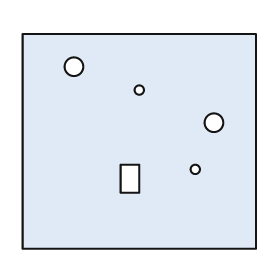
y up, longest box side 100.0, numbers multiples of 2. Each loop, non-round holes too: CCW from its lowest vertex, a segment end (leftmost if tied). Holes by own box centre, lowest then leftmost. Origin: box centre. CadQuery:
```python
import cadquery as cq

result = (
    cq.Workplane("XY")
    .moveTo(-50.0, -46.0)
    .lineTo(50.0, -46.0)
    .lineTo(50.0, 46.0)
    .lineTo(-50.0, 46.0)
    .close()
    .moveTo(-8.0, -22.0)
    .lineTo(0.0, -22.0)
    .lineTo(0.0, -10.0)
    .lineTo(-8.0, -10.0)
    .close()
    .moveTo(24.0, -12.0)
    .circle(2.0)
    .moveTo(32.0, 8.0)
    .circle(4.0)
    .moveTo(0.0, 22.0)
    .circle(2.0)
    .moveTo(-28.0, 32.0)
    .circle(4.0)
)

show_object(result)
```